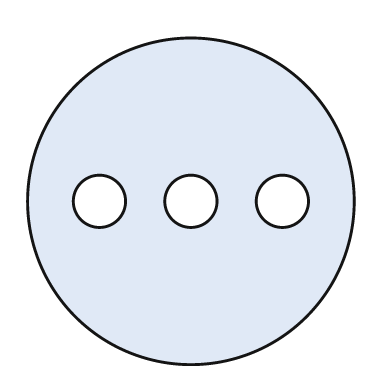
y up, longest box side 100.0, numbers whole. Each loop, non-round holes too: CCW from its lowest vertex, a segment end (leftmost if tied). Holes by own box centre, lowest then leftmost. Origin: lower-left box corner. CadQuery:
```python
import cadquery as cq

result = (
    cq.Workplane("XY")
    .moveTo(50.0, 50.0)
    .circle(50.0)
    .moveTo(22.0, 50.0)
    .circle(8.0)
    .moveTo(50.0, 50.0)
    .circle(8.0)
    .moveTo(78.0, 50.0)
    .circle(8.0)
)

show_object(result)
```